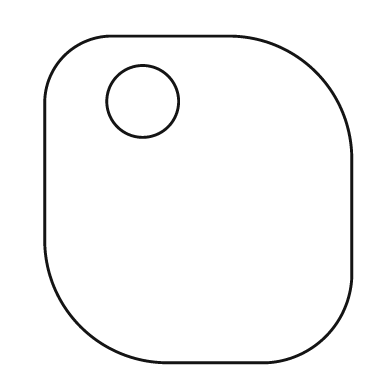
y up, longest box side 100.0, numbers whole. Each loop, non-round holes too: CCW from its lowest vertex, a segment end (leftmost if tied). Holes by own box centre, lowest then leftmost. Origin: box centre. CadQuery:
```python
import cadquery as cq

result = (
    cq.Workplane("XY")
    .moveTo(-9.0, -50.0)
    .lineTo(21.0, -50.0)
    .threePointArc((39.0, -42.0), (47.0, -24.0))
    .lineTo(47.0, 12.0)
    .threePointArc((36.0, 39.0), (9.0, 50.0))
    .lineTo(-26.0, 50.0)
    .threePointArc((-41.0, 44.0), (-47.0, 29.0))
    .lineTo(-47.0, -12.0)
    .threePointArc((-36.0, -39.0), (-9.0, -50.0))
    .close()
    .moveTo(-17.0, 30.0)
    .circle(11.0)
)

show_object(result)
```